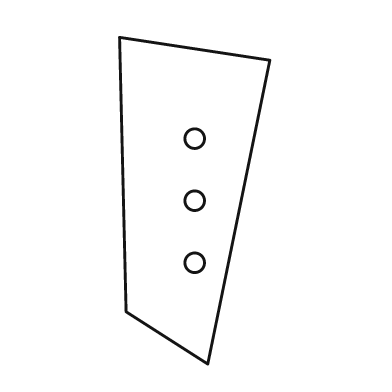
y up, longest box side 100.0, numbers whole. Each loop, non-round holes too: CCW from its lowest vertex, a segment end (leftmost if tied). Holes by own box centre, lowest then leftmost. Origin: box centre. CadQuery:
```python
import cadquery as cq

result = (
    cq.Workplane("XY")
    .moveTo(4.0, -50.0)
    .lineTo(23.0, 43.0)
    .lineTo(-23.0, 50.0)
    .lineTo(-21.0, -34.0)
    .close()
    .moveTo(0.0, -19.0)
    .circle(3.0)
    .moveTo(0.0, 0.0)
    .circle(3.0)
    .moveTo(0.0, 19.0)
    .circle(3.0)
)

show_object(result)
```